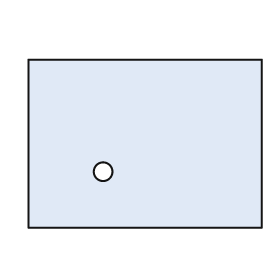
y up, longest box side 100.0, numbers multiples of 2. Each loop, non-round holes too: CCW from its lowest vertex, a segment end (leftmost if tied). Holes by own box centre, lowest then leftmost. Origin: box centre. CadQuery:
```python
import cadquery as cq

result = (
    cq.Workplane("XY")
    .moveTo(-50.0, -36.0)
    .lineTo(50.0, -36.0)
    .lineTo(50.0, 36.0)
    .lineTo(-50.0, 36.0)
    .close()
    .moveTo(-18.0, -12.0)
    .circle(4.0)
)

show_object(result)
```